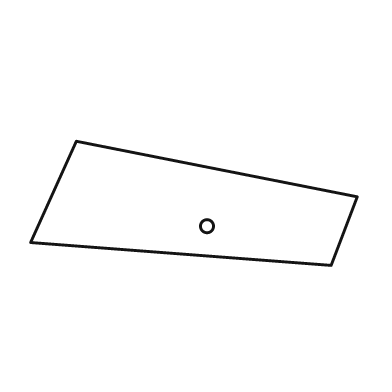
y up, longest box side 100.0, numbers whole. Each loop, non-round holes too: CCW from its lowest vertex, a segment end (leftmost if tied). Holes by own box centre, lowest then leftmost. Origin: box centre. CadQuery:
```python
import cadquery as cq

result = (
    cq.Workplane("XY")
    .moveTo(42.0, -19.0)
    .lineTo(50.0, 2.0)
    .lineTo(-36.0, 19.0)
    .lineTo(-50.0, -12.0)
    .close()
    .moveTo(4.0, -7.0)
    .circle(2.0)
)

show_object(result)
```